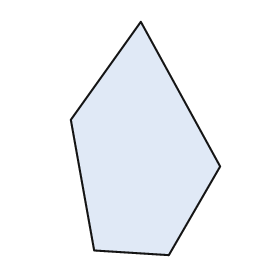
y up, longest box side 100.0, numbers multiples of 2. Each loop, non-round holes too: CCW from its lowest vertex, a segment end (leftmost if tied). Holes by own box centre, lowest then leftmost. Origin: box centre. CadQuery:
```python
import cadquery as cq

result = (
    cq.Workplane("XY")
    .moveTo(10.0, -50.0)
    .lineTo(32.0, -12.0)
    .lineTo(-2.0, 50.0)
    .lineTo(-32.0, 8.0)
    .lineTo(-22.0, -48.0)
    .close()
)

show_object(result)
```